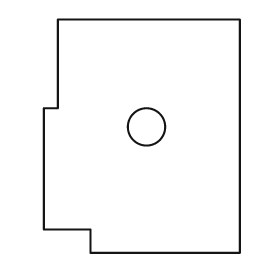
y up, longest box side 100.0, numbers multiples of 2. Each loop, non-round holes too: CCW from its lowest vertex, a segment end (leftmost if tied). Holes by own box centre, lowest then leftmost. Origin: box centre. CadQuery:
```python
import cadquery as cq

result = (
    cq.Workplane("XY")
    .moveTo(-22.0, -50.0)
    .lineTo(42.0, -50.0)
    .lineTo(42.0, 50.0)
    .lineTo(-36.0, 50.0)
    .lineTo(-36.0, 12.0)
    .lineTo(-42.0, 12.0)
    .lineTo(-42.0, -40.0)
    .lineTo(-22.0, -40.0)
    .close()
    .moveTo(2.0, 4.0)
    .circle(8.0)
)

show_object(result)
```